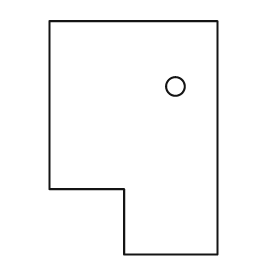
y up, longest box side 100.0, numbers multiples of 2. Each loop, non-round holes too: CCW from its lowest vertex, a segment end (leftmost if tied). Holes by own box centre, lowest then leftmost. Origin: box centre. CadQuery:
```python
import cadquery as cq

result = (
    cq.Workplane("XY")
    .moveTo(-4.0, -50.0)
    .lineTo(36.0, -50.0)
    .lineTo(36.0, 50.0)
    .lineTo(-36.0, 50.0)
    .lineTo(-36.0, -22.0)
    .lineTo(-4.0, -22.0)
    .close()
    .moveTo(18.0, 22.0)
    .circle(4.0)
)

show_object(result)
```